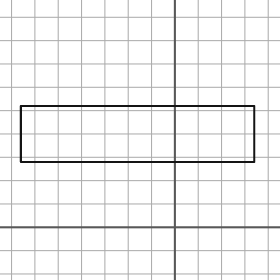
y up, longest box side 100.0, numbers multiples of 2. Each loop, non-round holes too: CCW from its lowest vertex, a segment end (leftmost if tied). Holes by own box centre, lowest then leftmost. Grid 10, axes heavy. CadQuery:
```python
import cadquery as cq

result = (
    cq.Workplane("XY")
    .moveTo(-66.0, 28.0)
    .lineTo(34.0, 28.0)
    .lineTo(34.0, 52.0)
    .lineTo(-66.0, 52.0)
    .close()
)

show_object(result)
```